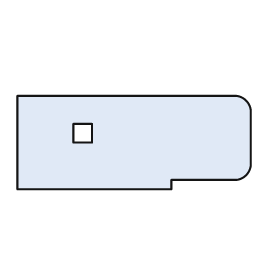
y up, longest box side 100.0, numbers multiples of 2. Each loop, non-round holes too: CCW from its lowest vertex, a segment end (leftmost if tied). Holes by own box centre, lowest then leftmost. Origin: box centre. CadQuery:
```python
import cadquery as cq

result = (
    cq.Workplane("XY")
    .moveTo(-50.0, -20.0)
    .lineTo(16.0, -20.0)
    .lineTo(16.0, -16.0)
    .lineTo(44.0, -16.0)
    .threePointArc((48.0, -14.0), (50.0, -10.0))
    .lineTo(50.0, 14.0)
    .threePointArc((48.0, 18.0), (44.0, 20.0))
    .lineTo(-50.0, 20.0)
    .close()
    .moveTo(-26.0, 0.0)
    .lineTo(-18.0, 0.0)
    .lineTo(-18.0, 8.0)
    .lineTo(-26.0, 8.0)
    .close()
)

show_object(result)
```